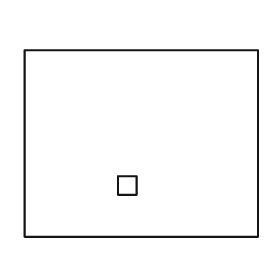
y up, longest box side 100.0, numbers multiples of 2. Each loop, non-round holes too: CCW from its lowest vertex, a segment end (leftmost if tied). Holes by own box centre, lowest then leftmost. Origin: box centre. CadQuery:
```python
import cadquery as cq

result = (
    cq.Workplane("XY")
    .moveTo(-50.0, -40.0)
    .lineTo(50.0, -40.0)
    .lineTo(50.0, 40.0)
    .lineTo(-50.0, 40.0)
    .close()
    .moveTo(-10.0, -22.0)
    .lineTo(-2.0, -22.0)
    .lineTo(-2.0, -14.0)
    .lineTo(-10.0, -14.0)
    .close()
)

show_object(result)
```